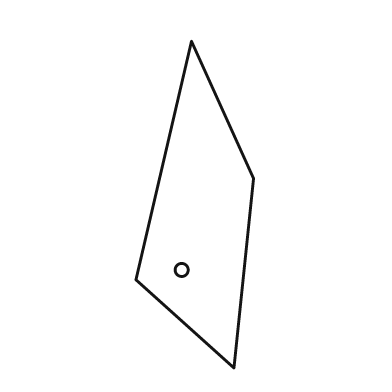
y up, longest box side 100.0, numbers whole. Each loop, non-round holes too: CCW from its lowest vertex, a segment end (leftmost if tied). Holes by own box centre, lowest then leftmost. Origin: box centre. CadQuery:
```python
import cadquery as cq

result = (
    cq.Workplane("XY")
    .moveTo(12.0, -50.0)
    .lineTo(18.0, 8.0)
    .lineTo(-1.0, 50.0)
    .lineTo(-18.0, -23.0)
    .close()
    .moveTo(-4.0, -20.0)
    .circle(2.0)
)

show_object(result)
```